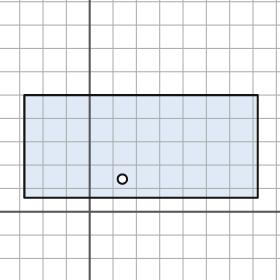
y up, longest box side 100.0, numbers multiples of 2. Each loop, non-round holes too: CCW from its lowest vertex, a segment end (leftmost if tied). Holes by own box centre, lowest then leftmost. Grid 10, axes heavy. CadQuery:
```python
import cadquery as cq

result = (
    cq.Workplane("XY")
    .moveTo(-28.0, 6.0)
    .lineTo(72.0, 6.0)
    .lineTo(72.0, 50.0)
    .lineTo(-28.0, 50.0)
    .close()
    .moveTo(14.0, 14.0)
    .circle(2.0)
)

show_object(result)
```